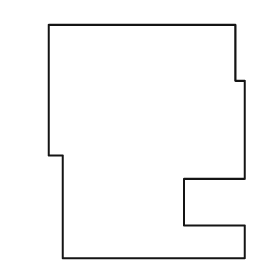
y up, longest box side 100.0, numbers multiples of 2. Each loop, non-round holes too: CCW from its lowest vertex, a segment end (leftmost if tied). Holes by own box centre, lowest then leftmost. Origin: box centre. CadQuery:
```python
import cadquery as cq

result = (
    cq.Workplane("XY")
    .moveTo(-36.0, -50.0)
    .lineTo(42.0, -50.0)
    .lineTo(42.0, -36.0)
    .lineTo(16.0, -36.0)
    .lineTo(16.0, -16.0)
    .lineTo(42.0, -16.0)
    .lineTo(42.0, 26.0)
    .lineTo(38.0, 26.0)
    .lineTo(38.0, 50.0)
    .lineTo(-42.0, 50.0)
    .lineTo(-42.0, -6.0)
    .lineTo(-36.0, -6.0)
    .close()
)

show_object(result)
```